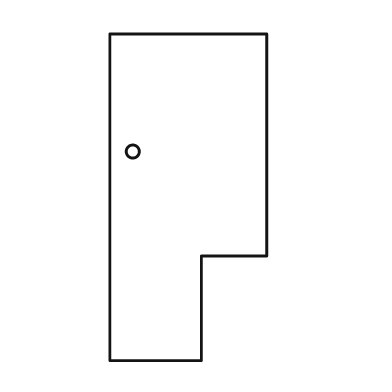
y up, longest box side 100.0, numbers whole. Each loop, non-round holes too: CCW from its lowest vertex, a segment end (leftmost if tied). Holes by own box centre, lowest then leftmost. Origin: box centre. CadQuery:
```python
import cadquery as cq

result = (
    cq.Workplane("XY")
    .moveTo(-24.0, -50.0)
    .lineTo(4.0, -50.0)
    .lineTo(4.0, -18.0)
    .lineTo(24.0, -18.0)
    .lineTo(24.0, 50.0)
    .lineTo(-24.0, 50.0)
    .close()
    .moveTo(-17.0, 14.0)
    .circle(2.0)
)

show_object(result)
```